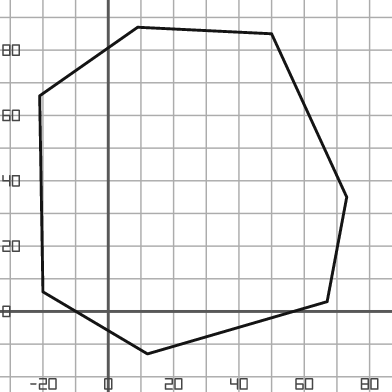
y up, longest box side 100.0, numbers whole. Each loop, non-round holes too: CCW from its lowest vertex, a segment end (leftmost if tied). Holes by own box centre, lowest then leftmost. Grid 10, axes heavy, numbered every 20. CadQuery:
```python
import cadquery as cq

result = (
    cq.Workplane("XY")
    .moveTo(12.0, -13.0)
    .lineTo(67.0, 3.0)
    .lineTo(73.0, 35.0)
    .lineTo(50.0, 85.0)
    .lineTo(9.0, 87.0)
    .lineTo(-21.0, 66.0)
    .lineTo(-20.0, 6.0)
    .close()
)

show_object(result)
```